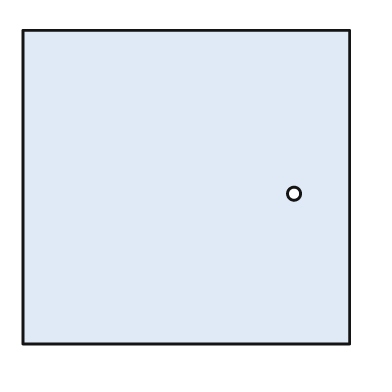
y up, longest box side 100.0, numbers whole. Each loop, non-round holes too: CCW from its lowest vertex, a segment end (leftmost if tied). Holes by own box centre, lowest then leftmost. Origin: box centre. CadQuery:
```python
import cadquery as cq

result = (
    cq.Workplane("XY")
    .moveTo(-50.0, -48.0)
    .lineTo(50.0, -48.0)
    .lineTo(50.0, 48.0)
    .lineTo(-50.0, 48.0)
    .close()
    .moveTo(33.0, -2.0)
    .circle(2.0)
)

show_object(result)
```